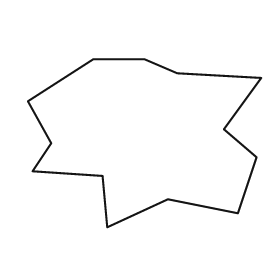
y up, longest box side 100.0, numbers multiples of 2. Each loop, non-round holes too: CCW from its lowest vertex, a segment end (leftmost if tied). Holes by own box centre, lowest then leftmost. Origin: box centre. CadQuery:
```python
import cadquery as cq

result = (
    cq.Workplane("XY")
    .moveTo(-16.0, -36.0)
    .lineTo(10.0, -24.0)
    .lineTo(40.0, -30.0)
    .lineTo(48.0, -6.0)
    .lineTo(34.0, 6.0)
    .lineTo(50.0, 28.0)
    .lineTo(14.0, 30.0)
    .lineTo(0.0, 36.0)
    .lineTo(-22.0, 36.0)
    .lineTo(-50.0, 18.0)
    .lineTo(-40.0, 0.0)
    .lineTo(-48.0, -12.0)
    .lineTo(-18.0, -14.0)
    .close()
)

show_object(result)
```